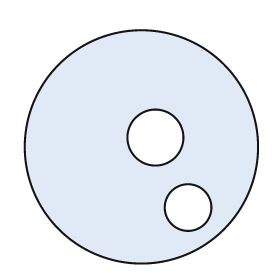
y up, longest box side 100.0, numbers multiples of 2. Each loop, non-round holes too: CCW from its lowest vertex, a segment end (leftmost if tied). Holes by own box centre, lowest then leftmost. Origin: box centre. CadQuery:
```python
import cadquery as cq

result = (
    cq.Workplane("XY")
    .moveTo(0.0, 0.0)
    .circle(50.0)
    .moveTo(20.0, -26.0)
    .circle(10.0)
    .moveTo(6.0, 4.0)
    .circle(12.0)
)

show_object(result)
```